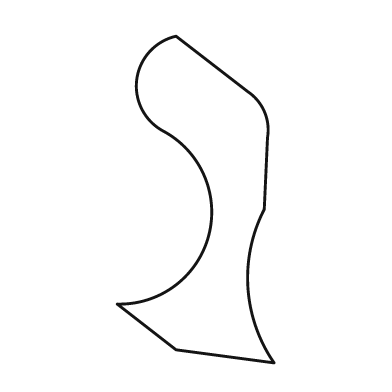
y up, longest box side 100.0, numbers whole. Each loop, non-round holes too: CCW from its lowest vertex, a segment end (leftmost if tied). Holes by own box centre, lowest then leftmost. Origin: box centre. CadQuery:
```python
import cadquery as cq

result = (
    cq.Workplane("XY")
    .moveTo(24.0, -50.0)
    .threePointArc((16.0, -27.0), (21.0, -3.0))
    .lineTo(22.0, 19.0)
    .threePointArc((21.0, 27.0), (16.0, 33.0))
    .lineTo(-6.0, 50.0)
    .threePointArc((-18.0, 37.0), (-10.0, 21.0))
    .threePointArc((4.0, -11.0), (-24.0, -32.0))
    .lineTo(-6.0, -46.0)
    .close()
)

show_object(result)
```